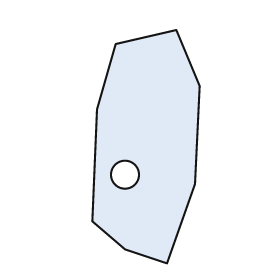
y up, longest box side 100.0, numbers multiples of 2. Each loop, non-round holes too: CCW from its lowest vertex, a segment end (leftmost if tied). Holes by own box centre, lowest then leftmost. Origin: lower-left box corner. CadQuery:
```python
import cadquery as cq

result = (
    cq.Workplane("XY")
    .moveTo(32.0, 0.0)
    .lineTo(44.0, 34.0)
    .lineTo(46.0, 76.0)
    .lineTo(36.0, 100.0)
    .lineTo(10.0, 94.0)
    .lineTo(2.0, 66.0)
    .lineTo(0.0, 18.0)
    .lineTo(14.0, 6.0)
    .close()
    .moveTo(14.0, 38.0)
    .circle(6.0)
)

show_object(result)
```